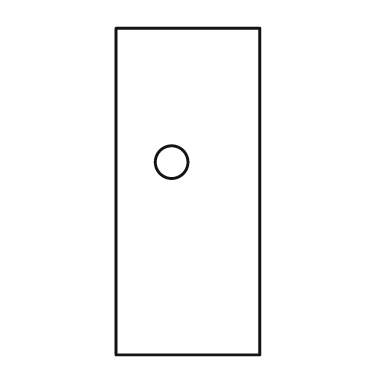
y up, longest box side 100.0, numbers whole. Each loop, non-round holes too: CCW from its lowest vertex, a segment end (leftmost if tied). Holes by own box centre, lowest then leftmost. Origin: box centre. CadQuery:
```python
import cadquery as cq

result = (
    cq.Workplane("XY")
    .moveTo(-22.0, -50.0)
    .lineTo(22.0, -50.0)
    .lineTo(22.0, 50.0)
    .lineTo(-22.0, 50.0)
    .close()
    .moveTo(-5.0, 9.0)
    .circle(5.0)
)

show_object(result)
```